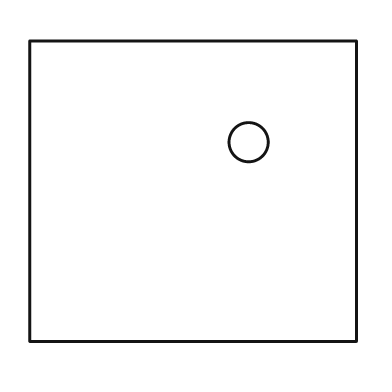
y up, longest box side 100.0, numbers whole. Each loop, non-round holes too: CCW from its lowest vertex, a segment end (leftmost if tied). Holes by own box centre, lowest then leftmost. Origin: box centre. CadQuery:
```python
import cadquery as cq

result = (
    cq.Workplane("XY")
    .moveTo(-50.0, -46.0)
    .lineTo(50.0, -46.0)
    .lineTo(50.0, 46.0)
    .lineTo(-50.0, 46.0)
    .close()
    .moveTo(17.0, 15.0)
    .circle(6.0)
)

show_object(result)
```